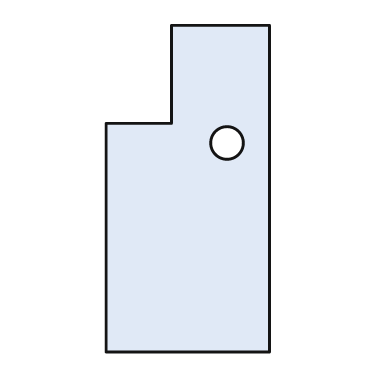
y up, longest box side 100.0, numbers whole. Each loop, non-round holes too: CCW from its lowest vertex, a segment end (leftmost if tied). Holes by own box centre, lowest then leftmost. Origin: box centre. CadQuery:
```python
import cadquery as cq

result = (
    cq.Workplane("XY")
    .moveTo(-25.0, -50.0)
    .lineTo(25.0, -50.0)
    .lineTo(25.0, 50.0)
    .lineTo(-5.0, 50.0)
    .lineTo(-5.0, 20.0)
    .lineTo(-25.0, 20.0)
    .close()
    .moveTo(12.0, 14.0)
    .circle(5.0)
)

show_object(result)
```